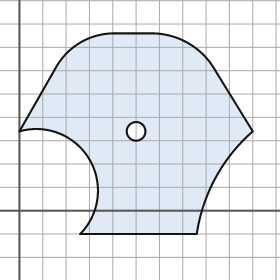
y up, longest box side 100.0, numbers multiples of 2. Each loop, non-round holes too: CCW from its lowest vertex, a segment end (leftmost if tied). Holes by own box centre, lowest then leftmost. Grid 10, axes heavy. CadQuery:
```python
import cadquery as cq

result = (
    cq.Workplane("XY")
    .moveTo(26.0, -10.0)
    .lineTo(76.0, -10.0)
    .threePointArc((84.0, 14.0), (100.0, 34.0))
    .lineTo(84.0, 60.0)
    .threePointArc((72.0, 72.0), (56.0, 76.0))
    .lineTo(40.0, 76.0)
    .threePointArc((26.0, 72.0), (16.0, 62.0))
    .lineTo(0.0, 34.0)
    .threePointArc((30.0, 22.0), (26.0, -10.0))
    .close()
    .moveTo(50.0, 34.0)
    .circle(4.0)
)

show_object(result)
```